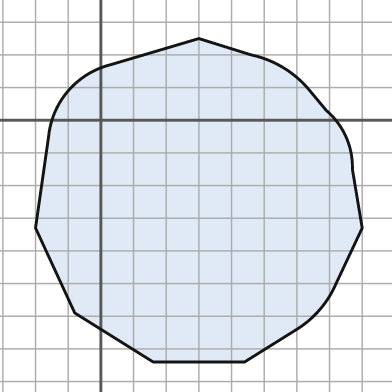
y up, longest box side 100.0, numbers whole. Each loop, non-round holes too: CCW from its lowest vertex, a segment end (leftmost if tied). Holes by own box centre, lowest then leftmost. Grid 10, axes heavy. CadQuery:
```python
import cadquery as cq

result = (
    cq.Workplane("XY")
    .moveTo(16.0, -74.0)
    .lineTo(44.0, -74.0)
    .lineTo(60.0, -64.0)
    .threePointArc((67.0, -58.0), (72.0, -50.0))
    .lineTo(80.0, -33.0)
    .lineTo(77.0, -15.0)
    .threePointArc((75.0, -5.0), (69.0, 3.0))
    .lineTo(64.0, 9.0)
    .threePointArc((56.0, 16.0), (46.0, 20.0))
    .lineTo(30.0, 25.0)
    .lineTo(3.0, 17.0)
    .threePointArc((-10.0, 9.0), (-16.0, -5.0))
    .lineTo(-20.0, -33.0)
    .lineTo(-8.0, -59.0)
    .close()
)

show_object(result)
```